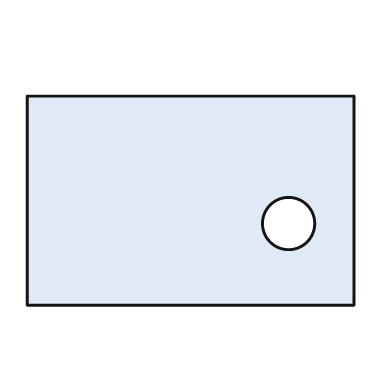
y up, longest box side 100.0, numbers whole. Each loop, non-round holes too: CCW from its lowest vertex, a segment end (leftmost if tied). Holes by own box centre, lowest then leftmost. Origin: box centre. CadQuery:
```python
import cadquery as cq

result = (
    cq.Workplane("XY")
    .moveTo(-50.0, -32.0)
    .lineTo(50.0, -32.0)
    .lineTo(50.0, 32.0)
    .lineTo(-50.0, 32.0)
    .close()
    .moveTo(30.0, -7.0)
    .circle(8.0)
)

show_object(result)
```